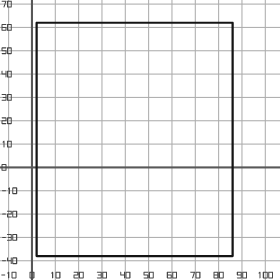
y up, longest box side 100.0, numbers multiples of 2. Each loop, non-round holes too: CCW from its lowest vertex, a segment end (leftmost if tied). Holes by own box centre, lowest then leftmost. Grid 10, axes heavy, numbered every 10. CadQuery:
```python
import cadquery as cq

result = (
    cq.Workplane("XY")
    .moveTo(2.0, -38.0)
    .lineTo(86.0, -38.0)
    .lineTo(86.0, 62.0)
    .lineTo(2.0, 62.0)
    .close()
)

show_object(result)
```